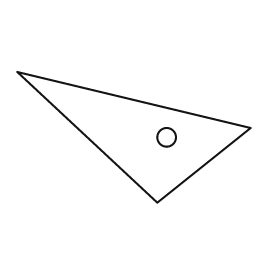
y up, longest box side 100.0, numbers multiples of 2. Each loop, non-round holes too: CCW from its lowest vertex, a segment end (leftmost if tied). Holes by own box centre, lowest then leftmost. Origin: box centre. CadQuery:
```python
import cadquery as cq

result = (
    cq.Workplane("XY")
    .moveTo(10.0, -28.0)
    .lineTo(50.0, 4.0)
    .lineTo(-50.0, 28.0)
    .close()
    .moveTo(14.0, 0.0)
    .circle(4.0)
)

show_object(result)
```